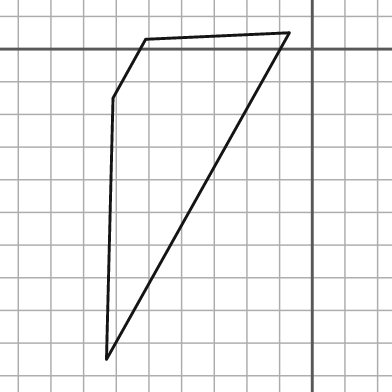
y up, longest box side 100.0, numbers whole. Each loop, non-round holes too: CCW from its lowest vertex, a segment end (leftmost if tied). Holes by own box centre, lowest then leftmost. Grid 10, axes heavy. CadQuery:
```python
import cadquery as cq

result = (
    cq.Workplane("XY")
    .moveTo(-63.0, -95.0)
    .lineTo(-7.0, 5.0)
    .lineTo(-51.0, 3.0)
    .lineTo(-61.0, -15.0)
    .close()
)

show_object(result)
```